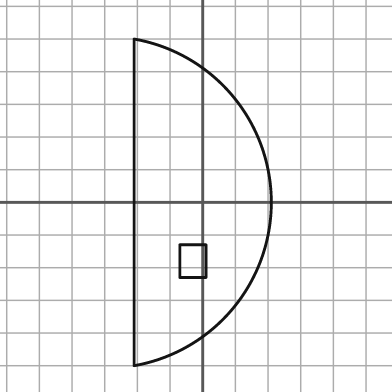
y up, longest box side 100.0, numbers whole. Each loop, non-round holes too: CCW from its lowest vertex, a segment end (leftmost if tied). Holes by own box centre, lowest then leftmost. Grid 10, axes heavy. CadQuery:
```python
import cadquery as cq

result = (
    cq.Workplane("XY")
    .moveTo(-21.0, -50.0)
    .threePointArc((21.0, 0.0), (-21.0, 50.0))
    .close()
    .moveTo(-7.0, -23.0)
    .lineTo(1.0, -23.0)
    .lineTo(1.0, -13.0)
    .lineTo(-7.0, -13.0)
    .close()
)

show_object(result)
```